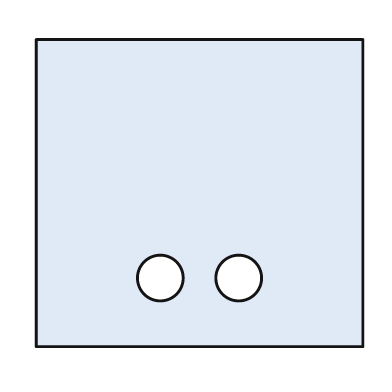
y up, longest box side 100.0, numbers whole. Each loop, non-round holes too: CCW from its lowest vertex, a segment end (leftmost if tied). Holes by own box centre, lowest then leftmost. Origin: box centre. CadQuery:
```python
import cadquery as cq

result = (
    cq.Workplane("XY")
    .moveTo(-50.0, -47.0)
    .lineTo(50.0, -47.0)
    .lineTo(50.0, 47.0)
    .lineTo(-50.0, 47.0)
    .close()
    .moveTo(-12.0, -26.0)
    .circle(7.0)
    .moveTo(12.0, -26.0)
    .circle(7.0)
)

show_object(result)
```